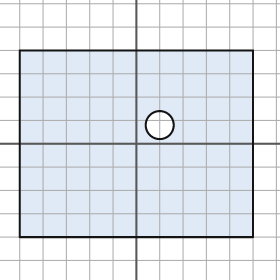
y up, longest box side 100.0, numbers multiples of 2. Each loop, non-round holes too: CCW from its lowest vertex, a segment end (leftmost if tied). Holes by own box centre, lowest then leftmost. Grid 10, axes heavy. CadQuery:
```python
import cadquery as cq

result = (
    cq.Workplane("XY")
    .moveTo(-50.0, -40.0)
    .lineTo(50.0, -40.0)
    .lineTo(50.0, 40.0)
    .lineTo(-50.0, 40.0)
    .close()
    .moveTo(10.0, 8.0)
    .circle(6.0)
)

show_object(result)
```